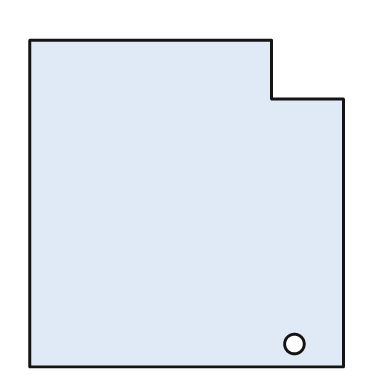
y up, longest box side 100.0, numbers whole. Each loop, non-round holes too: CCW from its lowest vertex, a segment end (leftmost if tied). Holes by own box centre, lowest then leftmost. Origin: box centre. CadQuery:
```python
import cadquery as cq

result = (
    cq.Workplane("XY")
    .moveTo(-48.0, -50.0)
    .lineTo(48.0, -50.0)
    .lineTo(48.0, 32.0)
    .lineTo(26.0, 32.0)
    .lineTo(26.0, 50.0)
    .lineTo(-48.0, 50.0)
    .close()
    .moveTo(33.0, -43.0)
    .circle(3.0)
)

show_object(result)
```